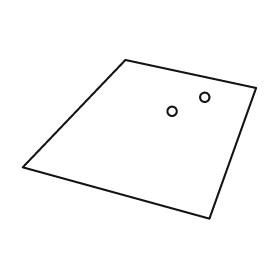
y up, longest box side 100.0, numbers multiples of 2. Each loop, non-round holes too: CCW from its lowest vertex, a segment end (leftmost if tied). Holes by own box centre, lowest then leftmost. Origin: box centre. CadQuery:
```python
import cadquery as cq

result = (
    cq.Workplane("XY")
    .moveTo(30.0, -34.0)
    .lineTo(50.0, 22.0)
    .lineTo(-6.0, 34.0)
    .lineTo(-50.0, -12.0)
    .close()
    .moveTo(14.0, 12.0)
    .circle(2.0)
    .moveTo(28.0, 18.0)
    .circle(2.0)
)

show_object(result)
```